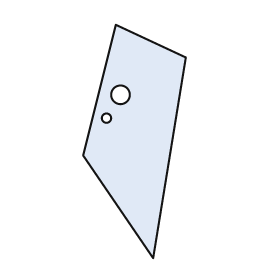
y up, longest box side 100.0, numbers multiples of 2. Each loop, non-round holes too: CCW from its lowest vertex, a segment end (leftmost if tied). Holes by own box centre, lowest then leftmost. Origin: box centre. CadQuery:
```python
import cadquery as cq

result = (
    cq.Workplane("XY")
    .moveTo(8.0, -50.0)
    .lineTo(22.0, 36.0)
    .lineTo(-8.0, 50.0)
    .lineTo(-22.0, -6.0)
    .close()
    .moveTo(-12.0, 10.0)
    .circle(2.0)
    .moveTo(-6.0, 20.0)
    .circle(4.0)
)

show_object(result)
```